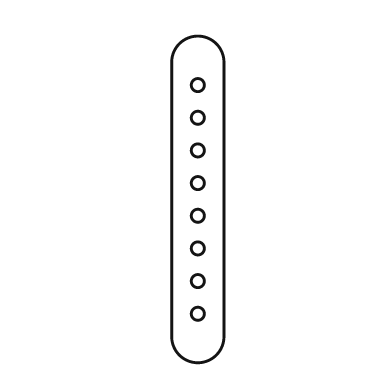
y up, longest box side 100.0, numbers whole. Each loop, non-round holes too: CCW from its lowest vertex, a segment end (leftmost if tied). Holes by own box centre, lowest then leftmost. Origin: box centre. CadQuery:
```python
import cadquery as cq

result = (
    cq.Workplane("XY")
    .moveTo(-8.0, -42.0)
    .threePointArc((0.0, -50.0), (8.0, -42.0))
    .lineTo(8.0, 42.0)
    .threePointArc((0.0, 50.0), (-8.0, 42.0))
    .close()
    .moveTo(0.0, -35.0)
    .circle(2.0)
    .moveTo(0.0, -25.0)
    .circle(2.0)
    .moveTo(0.0, -15.0)
    .circle(2.0)
    .moveTo(0.0, -5.0)
    .circle(2.0)
    .moveTo(0.0, 5.0)
    .circle(2.0)
    .moveTo(0.0, 15.0)
    .circle(2.0)
    .moveTo(0.0, 25.0)
    .circle(2.0)
    .moveTo(0.0, 35.0)
    .circle(2.0)
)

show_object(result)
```